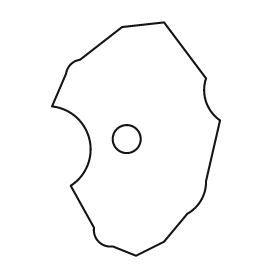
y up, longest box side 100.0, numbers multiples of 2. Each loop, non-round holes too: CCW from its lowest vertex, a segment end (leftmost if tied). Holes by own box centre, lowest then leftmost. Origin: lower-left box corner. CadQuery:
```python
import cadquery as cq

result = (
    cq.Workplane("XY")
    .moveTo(36.0, 0.0)
    .lineTo(48.0, 6.0)
    .lineTo(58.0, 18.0)
    .threePointArc((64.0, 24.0), (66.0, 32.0))
    .lineTo(72.0, 58.0)
    .threePointArc((66.0, 66.0), (66.0, 76.0))
    .lineTo(48.0, 100.0)
    .lineTo(30.0, 98.0)
    .lineTo(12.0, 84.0)
    .threePointArc((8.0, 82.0), (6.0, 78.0))
    .lineTo(0.0, 64.0)
    .threePointArc((16.0, 50.0), (8.0, 30.0))
    .lineTo(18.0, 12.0)
    .threePointArc((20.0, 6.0), (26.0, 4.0))
    .close()
    .moveTo(32.0, 50.0)
    .circle(6.0)
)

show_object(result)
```